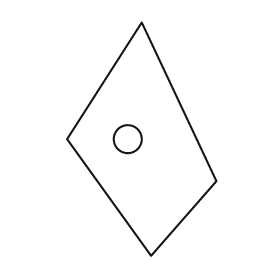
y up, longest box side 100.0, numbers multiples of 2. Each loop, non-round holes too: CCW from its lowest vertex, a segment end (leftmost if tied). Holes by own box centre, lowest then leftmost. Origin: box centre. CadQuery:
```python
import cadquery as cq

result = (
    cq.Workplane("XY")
    .moveTo(4.0, -50.0)
    .lineTo(32.0, -18.0)
    .lineTo(0.0, 50.0)
    .lineTo(-32.0, 0.0)
    .close()
    .moveTo(-6.0, 0.0)
    .circle(6.0)
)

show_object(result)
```